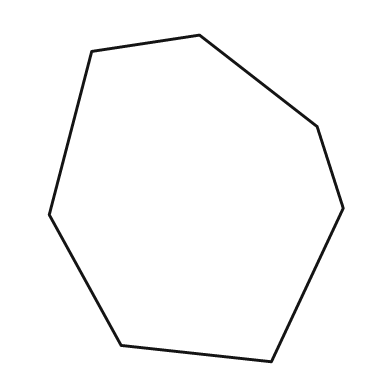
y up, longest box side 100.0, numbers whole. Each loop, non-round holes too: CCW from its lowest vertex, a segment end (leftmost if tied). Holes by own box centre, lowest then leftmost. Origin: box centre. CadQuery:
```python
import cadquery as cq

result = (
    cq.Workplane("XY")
    .moveTo(23.0, -50.0)
    .lineTo(45.0, -3.0)
    .lineTo(37.0, 22.0)
    .lineTo(1.0, 50.0)
    .lineTo(-32.0, 45.0)
    .lineTo(-45.0, -5.0)
    .lineTo(-23.0, -45.0)
    .close()
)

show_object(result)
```